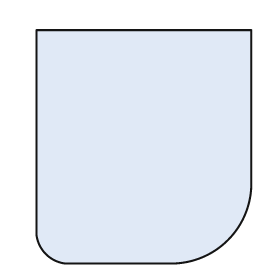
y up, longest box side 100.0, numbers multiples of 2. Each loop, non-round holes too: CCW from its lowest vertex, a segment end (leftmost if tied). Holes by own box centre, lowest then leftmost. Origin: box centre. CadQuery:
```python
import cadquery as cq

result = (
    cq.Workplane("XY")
    .moveTo(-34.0, -50.0)
    .lineTo(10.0, -50.0)
    .threePointArc((36.0, -40.0), (46.0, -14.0))
    .lineTo(46.0, 50.0)
    .lineTo(-46.0, 50.0)
    .lineTo(-46.0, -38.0)
    .threePointArc((-42.0, -46.0), (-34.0, -50.0))
    .close()
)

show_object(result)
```